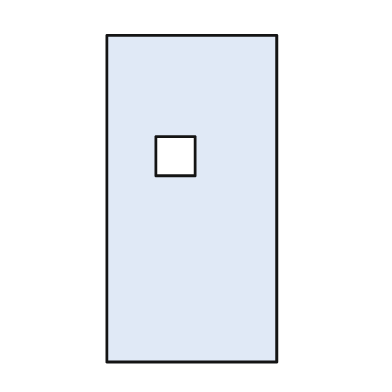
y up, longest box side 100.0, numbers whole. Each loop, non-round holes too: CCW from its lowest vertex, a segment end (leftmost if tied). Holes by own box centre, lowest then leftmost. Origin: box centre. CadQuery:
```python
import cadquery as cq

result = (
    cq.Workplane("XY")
    .moveTo(-26.0, -50.0)
    .lineTo(26.0, -50.0)
    .lineTo(26.0, 50.0)
    .lineTo(-26.0, 50.0)
    .close()
    .moveTo(-11.0, 7.0)
    .lineTo(1.0, 7.0)
    .lineTo(1.0, 19.0)
    .lineTo(-11.0, 19.0)
    .close()
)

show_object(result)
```